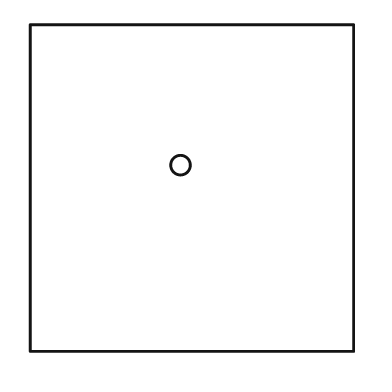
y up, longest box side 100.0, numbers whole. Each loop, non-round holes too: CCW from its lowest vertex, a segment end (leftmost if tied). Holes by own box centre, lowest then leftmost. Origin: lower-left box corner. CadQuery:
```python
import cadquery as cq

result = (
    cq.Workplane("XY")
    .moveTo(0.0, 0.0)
    .lineTo(99.0, 0.0)
    .lineTo(99.0, 100.0)
    .lineTo(0.0, 100.0)
    .close()
    .moveTo(46.0, 57.0)
    .circle(3.0)
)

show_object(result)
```